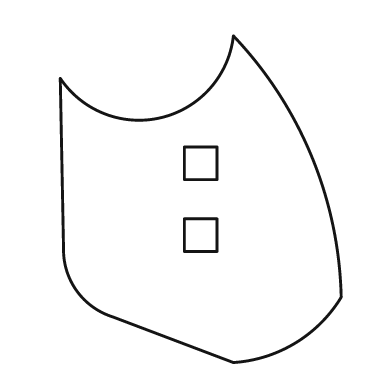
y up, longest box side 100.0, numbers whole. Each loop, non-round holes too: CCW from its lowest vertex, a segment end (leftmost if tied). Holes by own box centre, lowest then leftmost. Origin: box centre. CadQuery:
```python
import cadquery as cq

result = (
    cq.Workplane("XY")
    .moveTo(10.0, -50.0)
    .threePointArc((29.0, -44.0), (43.0, -30.0))
    .threePointArc((34.0, 13.0), (10.0, 50.0))
    .threePointArc((-12.0, 25.0), (-43.0, 37.0))
    .lineTo(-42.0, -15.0)
    .threePointArc((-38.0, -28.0), (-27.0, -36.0))
    .close()
    .moveTo(-5.0, -16.0)
    .lineTo(5.0, -16.0)
    .lineTo(5.0, -6.0)
    .lineTo(-5.0, -6.0)
    .close()
    .moveTo(-5.0, 6.0)
    .lineTo(5.0, 6.0)
    .lineTo(5.0, 16.0)
    .lineTo(-5.0, 16.0)
    .close()
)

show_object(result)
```